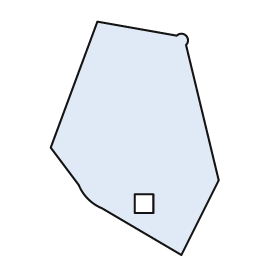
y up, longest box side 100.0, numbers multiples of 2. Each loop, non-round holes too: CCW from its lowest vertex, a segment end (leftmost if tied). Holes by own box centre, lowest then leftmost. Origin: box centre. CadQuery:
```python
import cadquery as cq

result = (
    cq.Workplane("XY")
    .moveTo(20.0, -50.0)
    .lineTo(36.0, -18.0)
    .lineTo(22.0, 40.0)
    .threePointArc((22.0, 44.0), (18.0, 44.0))
    .lineTo(-16.0, 50.0)
    .lineTo(-36.0, -4.0)
    .lineTo(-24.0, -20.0)
    .threePointArc((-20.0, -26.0), (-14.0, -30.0))
    .close()
    .moveTo(0.0, -32.0)
    .lineTo(8.0, -32.0)
    .lineTo(8.0, -24.0)
    .lineTo(0.0, -24.0)
    .close()
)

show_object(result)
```